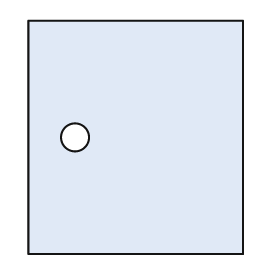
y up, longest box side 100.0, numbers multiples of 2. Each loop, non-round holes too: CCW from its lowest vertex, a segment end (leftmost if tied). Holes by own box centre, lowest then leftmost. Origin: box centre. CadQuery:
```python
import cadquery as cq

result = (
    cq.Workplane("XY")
    .moveTo(-46.0, -50.0)
    .lineTo(46.0, -50.0)
    .lineTo(46.0, 50.0)
    .lineTo(-46.0, 50.0)
    .close()
    .moveTo(-26.0, 0.0)
    .circle(6.0)
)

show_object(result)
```